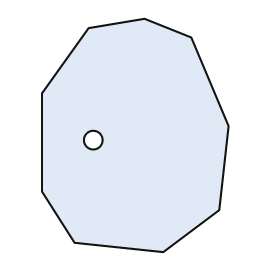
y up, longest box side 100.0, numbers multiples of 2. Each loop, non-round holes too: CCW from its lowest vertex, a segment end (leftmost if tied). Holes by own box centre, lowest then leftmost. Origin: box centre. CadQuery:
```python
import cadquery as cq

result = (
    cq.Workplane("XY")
    .moveTo(12.0, -50.0)
    .lineTo(36.0, -32.0)
    .lineTo(40.0, 4.0)
    .lineTo(24.0, 42.0)
    .lineTo(4.0, 50.0)
    .lineTo(-20.0, 46.0)
    .lineTo(-40.0, 18.0)
    .lineTo(-40.0, -24.0)
    .lineTo(-26.0, -46.0)
    .close()
    .moveTo(-18.0, -2.0)
    .circle(4.0)
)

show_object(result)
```